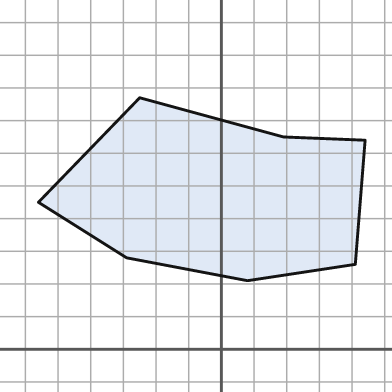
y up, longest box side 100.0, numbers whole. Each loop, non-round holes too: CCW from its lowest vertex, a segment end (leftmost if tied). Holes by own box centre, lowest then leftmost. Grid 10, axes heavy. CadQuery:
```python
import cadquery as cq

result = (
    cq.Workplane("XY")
    .moveTo(8.0, 21.0)
    .lineTo(41.0, 26.0)
    .lineTo(44.0, 64.0)
    .lineTo(19.0, 65.0)
    .lineTo(-25.0, 77.0)
    .lineTo(-56.0, 45.0)
    .lineTo(-29.0, 28.0)
    .close()
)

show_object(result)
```